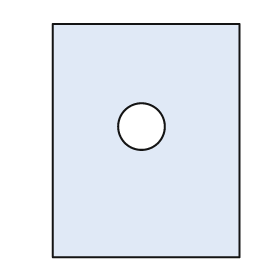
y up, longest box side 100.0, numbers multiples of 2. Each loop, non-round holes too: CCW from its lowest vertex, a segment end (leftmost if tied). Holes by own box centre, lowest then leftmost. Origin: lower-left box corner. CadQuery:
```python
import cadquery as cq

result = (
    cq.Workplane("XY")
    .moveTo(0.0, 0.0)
    .lineTo(80.0, 0.0)
    .lineTo(80.0, 100.0)
    .lineTo(0.0, 100.0)
    .close()
    .moveTo(38.0, 56.0)
    .circle(10.0)
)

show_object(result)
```